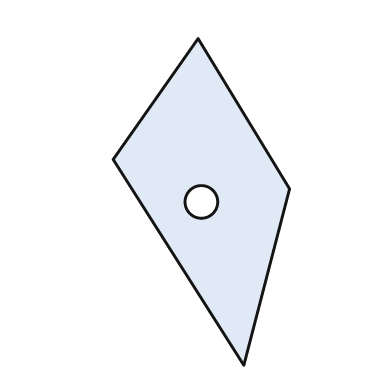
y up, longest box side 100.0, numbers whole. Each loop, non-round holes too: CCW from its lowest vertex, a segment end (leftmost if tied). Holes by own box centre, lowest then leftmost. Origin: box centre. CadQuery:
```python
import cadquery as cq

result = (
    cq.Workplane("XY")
    .moveTo(13.0, -50.0)
    .lineTo(27.0, 4.0)
    .lineTo(-1.0, 50.0)
    .lineTo(-27.0, 13.0)
    .close()
    .moveTo(0.0, 0.0)
    .circle(5.0)
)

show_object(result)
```